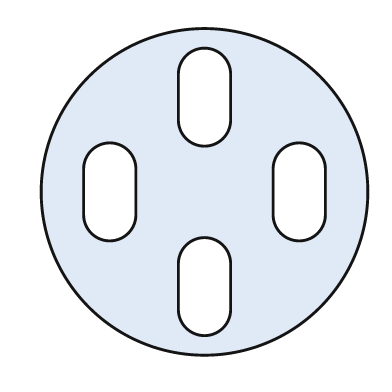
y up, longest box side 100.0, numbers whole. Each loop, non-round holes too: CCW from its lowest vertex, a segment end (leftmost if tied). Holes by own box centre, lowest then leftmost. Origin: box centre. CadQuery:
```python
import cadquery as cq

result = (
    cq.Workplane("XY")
    .moveTo(0.0, 0.0)
    .circle(50.0)
    .moveTo(-8.0, -36.0)
    .threePointArc((0.0, -44.0), (8.0, -36.0))
    .lineTo(8.0, -22.0)
    .threePointArc((0.0, -14.0), (-8.0, -22.0))
    .close()
    .moveTo(-37.0, -7.0)
    .threePointArc((-29.0, -15.0), (-21.0, -7.0))
    .lineTo(-21.0, 7.0)
    .threePointArc((-29.0, 15.0), (-37.0, 7.0))
    .close()
    .moveTo(21.0, -7.0)
    .threePointArc((29.0, -15.0), (37.0, -7.0))
    .lineTo(37.0, 7.0)
    .threePointArc((29.0, 15.0), (21.0, 7.0))
    .close()
    .moveTo(-8.0, 22.0)
    .threePointArc((0.0, 14.0), (8.0, 22.0))
    .lineTo(8.0, 36.0)
    .threePointArc((0.0, 44.0), (-8.0, 36.0))
    .close()
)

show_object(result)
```